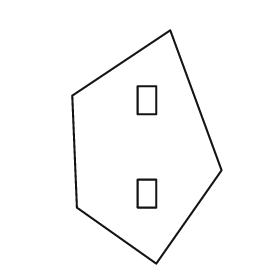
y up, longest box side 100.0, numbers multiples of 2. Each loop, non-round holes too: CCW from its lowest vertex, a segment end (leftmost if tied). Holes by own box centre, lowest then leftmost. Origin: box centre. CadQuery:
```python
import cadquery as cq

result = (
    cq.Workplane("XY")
    .moveTo(4.0, -50.0)
    .lineTo(32.0, -10.0)
    .lineTo(10.0, 50.0)
    .lineTo(-32.0, 22.0)
    .lineTo(-30.0, -26.0)
    .close()
    .moveTo(-4.0, -26.0)
    .lineTo(4.0, -26.0)
    .lineTo(4.0, -14.0)
    .lineTo(-4.0, -14.0)
    .close()
    .moveTo(-4.0, 14.0)
    .lineTo(4.0, 14.0)
    .lineTo(4.0, 26.0)
    .lineTo(-4.0, 26.0)
    .close()
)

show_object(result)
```